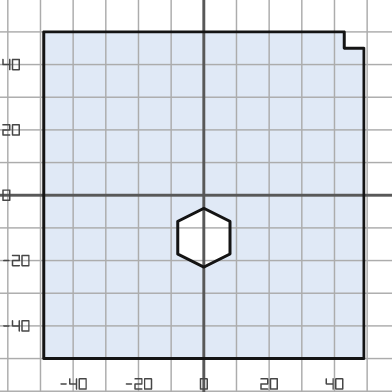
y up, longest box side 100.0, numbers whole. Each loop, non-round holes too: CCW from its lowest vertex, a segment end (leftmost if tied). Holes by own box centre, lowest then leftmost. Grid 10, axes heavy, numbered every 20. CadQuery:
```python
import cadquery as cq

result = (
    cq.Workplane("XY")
    .moveTo(-49.0, -50.0)
    .lineTo(49.0, -50.0)
    .lineTo(49.0, 45.0)
    .lineTo(43.0, 45.0)
    .lineTo(43.0, 50.0)
    .lineTo(-49.0, 50.0)
    .close()
    .moveTo(0.0, -22.0)
    .lineTo(8.0, -18.0)
    .lineTo(8.0, -8.0)
    .lineTo(0.0, -4.0)
    .lineTo(-8.0, -8.0)
    .lineTo(-8.0, -18.0)
    .close()
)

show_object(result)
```